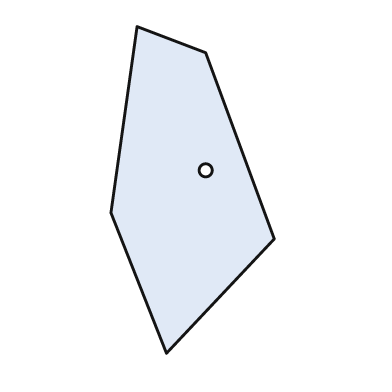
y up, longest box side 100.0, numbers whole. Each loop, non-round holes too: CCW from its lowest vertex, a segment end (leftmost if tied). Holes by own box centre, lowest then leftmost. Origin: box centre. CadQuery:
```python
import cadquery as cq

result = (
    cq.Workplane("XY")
    .moveTo(-8.0, -50.0)
    .lineTo(25.0, -15.0)
    .lineTo(4.0, 42.0)
    .lineTo(-17.0, 50.0)
    .lineTo(-25.0, -7.0)
    .close()
    .moveTo(4.0, 6.0)
    .circle(2.0)
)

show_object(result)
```